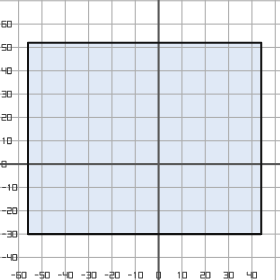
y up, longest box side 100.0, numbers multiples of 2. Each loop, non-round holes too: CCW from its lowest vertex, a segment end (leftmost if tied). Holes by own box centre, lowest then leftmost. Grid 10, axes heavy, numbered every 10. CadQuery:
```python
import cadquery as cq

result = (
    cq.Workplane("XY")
    .moveTo(-56.0, -30.0)
    .lineTo(44.0, -30.0)
    .lineTo(44.0, 52.0)
    .lineTo(-56.0, 52.0)
    .close()
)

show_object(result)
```